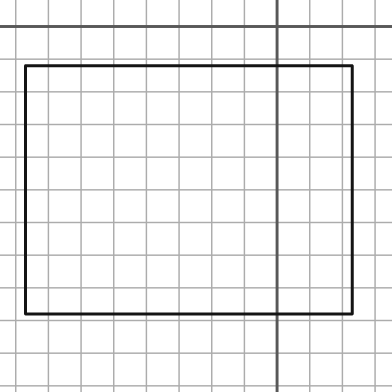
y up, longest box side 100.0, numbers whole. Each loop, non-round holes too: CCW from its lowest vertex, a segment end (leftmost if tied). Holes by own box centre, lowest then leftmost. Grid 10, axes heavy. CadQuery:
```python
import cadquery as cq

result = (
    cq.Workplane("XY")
    .moveTo(-77.0, -88.0)
    .lineTo(23.0, -88.0)
    .lineTo(23.0, -12.0)
    .lineTo(-77.0, -12.0)
    .close()
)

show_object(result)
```